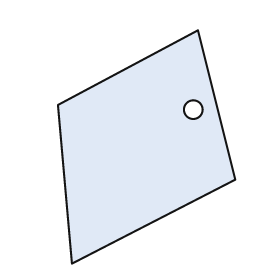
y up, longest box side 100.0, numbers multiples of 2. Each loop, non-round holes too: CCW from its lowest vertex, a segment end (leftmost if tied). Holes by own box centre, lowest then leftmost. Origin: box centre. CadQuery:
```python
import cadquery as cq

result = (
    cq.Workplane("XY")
    .moveTo(-32.0, -50.0)
    .lineTo(38.0, -14.0)
    .lineTo(22.0, 50.0)
    .lineTo(-38.0, 18.0)
    .close()
    .moveTo(20.0, 16.0)
    .circle(4.0)
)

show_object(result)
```